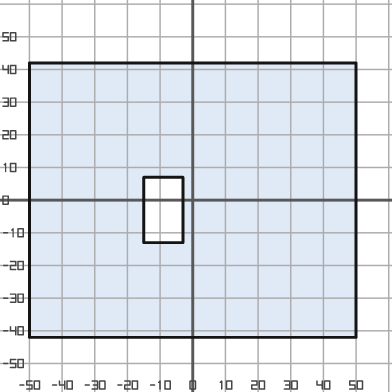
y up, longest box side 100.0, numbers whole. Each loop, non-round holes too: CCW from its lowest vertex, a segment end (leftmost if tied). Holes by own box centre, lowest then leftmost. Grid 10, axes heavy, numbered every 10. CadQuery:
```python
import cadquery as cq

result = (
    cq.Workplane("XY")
    .moveTo(-50.0, -42.0)
    .lineTo(50.0, -42.0)
    .lineTo(50.0, 42.0)
    .lineTo(-50.0, 42.0)
    .close()
    .moveTo(-15.0, -13.0)
    .lineTo(-3.0, -13.0)
    .lineTo(-3.0, 7.0)
    .lineTo(-15.0, 7.0)
    .close()
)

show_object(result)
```